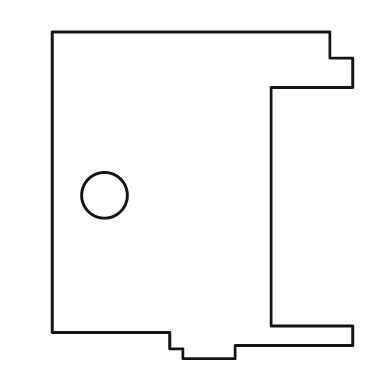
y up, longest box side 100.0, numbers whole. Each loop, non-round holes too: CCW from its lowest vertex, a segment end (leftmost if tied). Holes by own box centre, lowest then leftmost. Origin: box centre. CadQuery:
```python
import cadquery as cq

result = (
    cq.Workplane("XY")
    .moveTo(-6.0, -50.0)
    .lineTo(10.0, -50.0)
    .lineTo(10.0, -46.0)
    .lineTo(46.0, -46.0)
    .lineTo(46.0, -40.0)
    .lineTo(21.0, -40.0)
    .lineTo(21.0, 33.0)
    .lineTo(46.0, 33.0)
    .lineTo(46.0, 42.0)
    .lineTo(39.0, 42.0)
    .lineTo(39.0, 50.0)
    .lineTo(-46.0, 50.0)
    .lineTo(-46.0, -42.0)
    .lineTo(-10.0, -42.0)
    .lineTo(-10.0, -47.0)
    .lineTo(-6.0, -47.0)
    .close()
    .moveTo(-30.0, 0.0)
    .circle(7.0)
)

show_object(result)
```